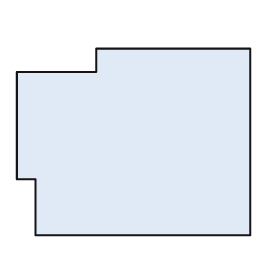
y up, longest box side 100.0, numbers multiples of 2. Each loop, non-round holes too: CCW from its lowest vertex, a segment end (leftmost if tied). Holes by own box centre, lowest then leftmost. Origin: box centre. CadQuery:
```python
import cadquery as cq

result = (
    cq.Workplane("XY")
    .moveTo(-42.0, -40.0)
    .lineTo(50.0, -40.0)
    .lineTo(50.0, 40.0)
    .lineTo(-16.0, 40.0)
    .lineTo(-16.0, 30.0)
    .lineTo(-50.0, 30.0)
    .lineTo(-50.0, -16.0)
    .lineTo(-42.0, -16.0)
    .close()
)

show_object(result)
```